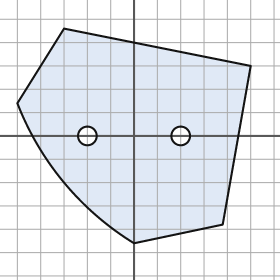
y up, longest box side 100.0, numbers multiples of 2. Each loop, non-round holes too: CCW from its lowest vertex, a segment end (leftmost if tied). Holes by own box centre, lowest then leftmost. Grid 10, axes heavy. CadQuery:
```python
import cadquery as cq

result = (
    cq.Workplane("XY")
    .moveTo(0.0, -46.0)
    .lineTo(38.0, -38.0)
    .lineTo(50.0, 30.0)
    .lineTo(-30.0, 46.0)
    .lineTo(-50.0, 14.0)
    .threePointArc((-30.0, -20.0), (0.0, -46.0))
    .close()
    .moveTo(-20.0, 0.0)
    .circle(4.0)
    .moveTo(20.0, 0.0)
    .circle(4.0)
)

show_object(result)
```